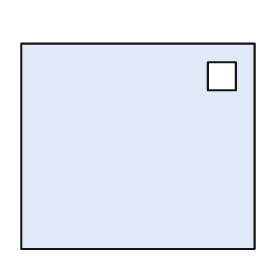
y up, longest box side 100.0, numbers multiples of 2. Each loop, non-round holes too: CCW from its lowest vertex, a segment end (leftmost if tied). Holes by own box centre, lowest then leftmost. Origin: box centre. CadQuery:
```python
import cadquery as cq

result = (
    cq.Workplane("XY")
    .moveTo(-50.0, -44.0)
    .lineTo(50.0, -44.0)
    .lineTo(50.0, 44.0)
    .lineTo(-50.0, 44.0)
    .close()
    .moveTo(30.0, 24.0)
    .lineTo(42.0, 24.0)
    .lineTo(42.0, 36.0)
    .lineTo(30.0, 36.0)
    .close()
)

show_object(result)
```